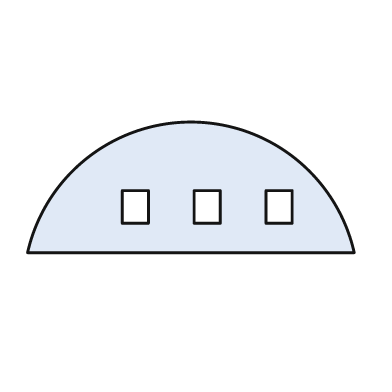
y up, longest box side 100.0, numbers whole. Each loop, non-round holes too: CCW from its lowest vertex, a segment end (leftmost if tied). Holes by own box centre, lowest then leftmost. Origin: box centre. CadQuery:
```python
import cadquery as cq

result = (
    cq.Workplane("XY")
    .moveTo(-50.0, -20.0)
    .lineTo(50.0, -20.0)
    .threePointArc((0.0, 20.0), (-50.0, -20.0))
    .close()
    .moveTo(-21.0, -11.0)
    .lineTo(-13.0, -11.0)
    .lineTo(-13.0, -1.0)
    .lineTo(-21.0, -1.0)
    .close()
    .moveTo(1.0, -11.0)
    .lineTo(9.0, -11.0)
    .lineTo(9.0, -1.0)
    .lineTo(1.0, -1.0)
    .close()
    .moveTo(23.0, -11.0)
    .lineTo(31.0, -11.0)
    .lineTo(31.0, -1.0)
    .lineTo(23.0, -1.0)
    .close()
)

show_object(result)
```